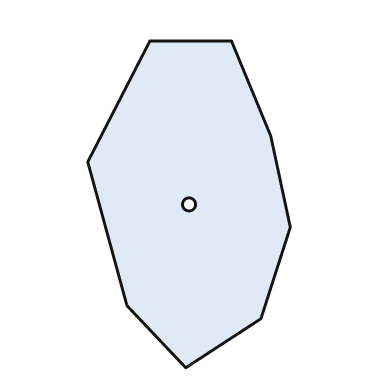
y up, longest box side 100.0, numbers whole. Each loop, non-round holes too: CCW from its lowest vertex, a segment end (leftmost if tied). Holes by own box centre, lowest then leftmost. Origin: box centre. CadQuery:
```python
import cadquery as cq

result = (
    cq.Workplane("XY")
    .moveTo(-1.0, -50.0)
    .lineTo(22.0, -35.0)
    .lineTo(31.0, -7.0)
    .lineTo(25.0, 21.0)
    .lineTo(13.0, 50.0)
    .lineTo(-12.0, 50.0)
    .lineTo(-31.0, 13.0)
    .lineTo(-19.0, -31.0)
    .close()
    .moveTo(0.0, 0.0)
    .circle(2.0)
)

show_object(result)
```